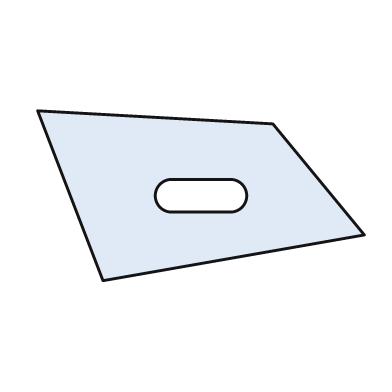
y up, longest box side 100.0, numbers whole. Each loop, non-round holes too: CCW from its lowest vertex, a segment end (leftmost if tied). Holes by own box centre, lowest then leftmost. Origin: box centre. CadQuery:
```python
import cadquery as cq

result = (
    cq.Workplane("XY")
    .moveTo(-30.0, -26.0)
    .lineTo(50.0, -12.0)
    .lineTo(22.0, 22.0)
    .lineTo(-50.0, 26.0)
    .close()
    .moveTo(-9.0, -5.0)
    .lineTo(9.0, -5.0)
    .threePointArc((14.0, 0.0), (9.0, 5.0))
    .lineTo(-9.0, 5.0)
    .threePointArc((-14.0, 0.0), (-9.0, -5.0))
    .close()
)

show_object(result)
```